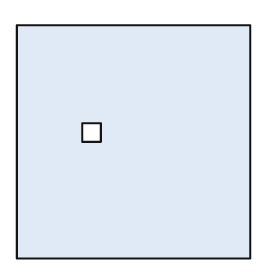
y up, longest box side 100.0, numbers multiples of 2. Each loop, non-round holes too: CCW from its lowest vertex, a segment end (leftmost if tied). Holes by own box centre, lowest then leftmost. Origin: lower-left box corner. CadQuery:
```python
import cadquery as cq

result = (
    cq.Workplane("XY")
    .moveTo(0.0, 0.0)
    .lineTo(100.0, 0.0)
    .lineTo(100.0, 100.0)
    .lineTo(0.0, 100.0)
    .close()
    .moveTo(28.0, 50.0)
    .lineTo(36.0, 50.0)
    .lineTo(36.0, 58.0)
    .lineTo(28.0, 58.0)
    .close()
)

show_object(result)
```